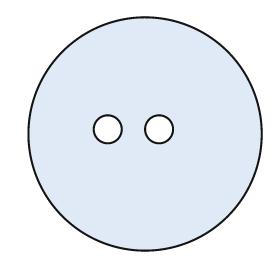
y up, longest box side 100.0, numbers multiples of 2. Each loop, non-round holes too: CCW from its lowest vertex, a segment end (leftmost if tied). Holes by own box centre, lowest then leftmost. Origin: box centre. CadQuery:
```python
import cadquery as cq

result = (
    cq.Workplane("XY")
    .moveTo(0.0, 0.0)
    .circle(50.0)
    .moveTo(-16.0, 2.0)
    .circle(6.0)
    .moveTo(6.0, 2.0)
    .circle(6.0)
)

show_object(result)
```